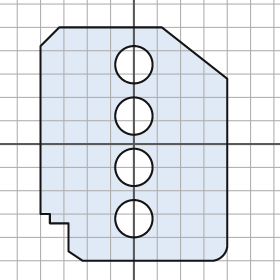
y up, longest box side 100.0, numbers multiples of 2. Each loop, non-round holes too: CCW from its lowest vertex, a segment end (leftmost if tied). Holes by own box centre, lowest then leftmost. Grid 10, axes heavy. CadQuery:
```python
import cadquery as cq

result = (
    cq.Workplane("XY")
    .moveTo(-22.0, -50.0)
    .lineTo(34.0, -50.0)
    .threePointArc((38.0, -48.0), (40.0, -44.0))
    .lineTo(40.0, 28.0)
    .lineTo(12.0, 50.0)
    .lineTo(-32.0, 50.0)
    .lineTo(-40.0, 42.0)
    .lineTo(-40.0, -30.0)
    .lineTo(-36.0, -30.0)
    .lineTo(-36.0, -34.0)
    .lineTo(-28.0, -34.0)
    .lineTo(-28.0, -46.0)
    .close()
    .moveTo(0.0, -32.0)
    .circle(8.0)
    .moveTo(0.0, -10.0)
    .circle(8.0)
    .moveTo(0.0, 12.0)
    .circle(8.0)
    .moveTo(0.0, 34.0)
    .circle(8.0)
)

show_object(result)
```